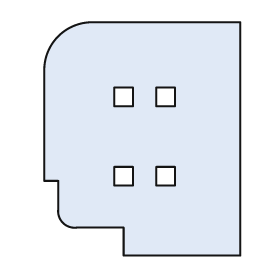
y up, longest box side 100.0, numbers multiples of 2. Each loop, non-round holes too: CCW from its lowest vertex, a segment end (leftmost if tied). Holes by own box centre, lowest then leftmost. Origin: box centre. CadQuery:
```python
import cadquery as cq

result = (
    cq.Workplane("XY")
    .moveTo(-8.0, -50.0)
    .lineTo(42.0, -50.0)
    .lineTo(42.0, 50.0)
    .lineTo(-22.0, 50.0)
    .threePointArc((-36.0, 44.0), (-42.0, 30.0))
    .lineTo(-42.0, -18.0)
    .lineTo(-36.0, -18.0)
    .lineTo(-36.0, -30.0)
    .threePointArc((-34.0, -36.0), (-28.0, -38.0))
    .lineTo(-8.0, -38.0)
    .close()
    .moveTo(-12.0, -20.0)
    .lineTo(-4.0, -20.0)
    .lineTo(-4.0, -12.0)
    .lineTo(-12.0, -12.0)
    .close()
    .moveTo(6.0, -20.0)
    .lineTo(14.0, -20.0)
    .lineTo(14.0, -12.0)
    .lineTo(6.0, -12.0)
    .close()
    .moveTo(-12.0, 14.0)
    .lineTo(-4.0, 14.0)
    .lineTo(-4.0, 22.0)
    .lineTo(-12.0, 22.0)
    .close()
    .moveTo(6.0, 14.0)
    .lineTo(14.0, 14.0)
    .lineTo(14.0, 22.0)
    .lineTo(6.0, 22.0)
    .close()
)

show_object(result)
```